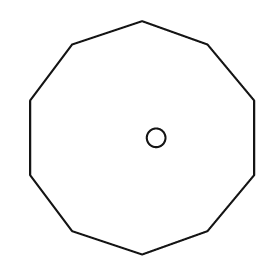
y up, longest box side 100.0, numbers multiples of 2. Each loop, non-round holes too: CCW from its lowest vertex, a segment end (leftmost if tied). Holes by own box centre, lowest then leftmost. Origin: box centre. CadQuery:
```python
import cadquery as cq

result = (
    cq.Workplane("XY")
    .moveTo(0.0, -50.0)
    .lineTo(28.0, -40.0)
    .lineTo(48.0, -16.0)
    .lineTo(48.0, 16.0)
    .lineTo(28.0, 40.0)
    .lineTo(0.0, 50.0)
    .lineTo(-30.0, 40.0)
    .lineTo(-48.0, 16.0)
    .lineTo(-48.0, -16.0)
    .lineTo(-30.0, -40.0)
    .close()
    .moveTo(6.0, 0.0)
    .circle(4.0)
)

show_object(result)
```